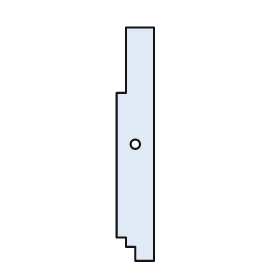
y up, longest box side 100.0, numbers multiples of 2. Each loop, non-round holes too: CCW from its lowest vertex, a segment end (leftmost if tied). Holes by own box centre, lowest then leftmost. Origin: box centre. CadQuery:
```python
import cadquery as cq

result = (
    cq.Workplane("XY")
    .moveTo(0.0, -50.0)
    .lineTo(8.0, -50.0)
    .lineTo(8.0, 50.0)
    .lineTo(-4.0, 50.0)
    .lineTo(-4.0, 22.0)
    .lineTo(-8.0, 22.0)
    .lineTo(-8.0, -40.0)
    .lineTo(-4.0, -40.0)
    .lineTo(-4.0, -44.0)
    .lineTo(0.0, -44.0)
    .close()
    .moveTo(0.0, 0.0)
    .circle(2.0)
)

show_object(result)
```